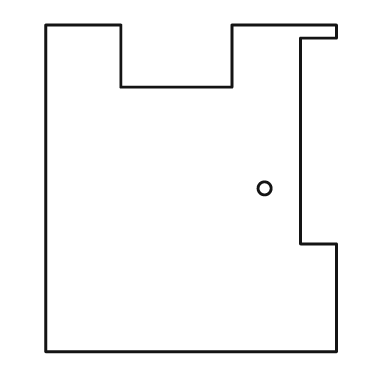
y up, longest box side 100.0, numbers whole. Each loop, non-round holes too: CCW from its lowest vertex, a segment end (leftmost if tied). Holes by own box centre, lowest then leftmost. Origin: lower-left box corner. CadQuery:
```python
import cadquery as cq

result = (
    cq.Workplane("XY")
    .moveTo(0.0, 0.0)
    .lineTo(89.0, 0.0)
    .lineTo(89.0, 33.0)
    .lineTo(78.0, 33.0)
    .lineTo(78.0, 96.0)
    .lineTo(89.0, 96.0)
    .lineTo(89.0, 100.0)
    .lineTo(57.0, 100.0)
    .lineTo(57.0, 81.0)
    .lineTo(23.0, 81.0)
    .lineTo(23.0, 100.0)
    .lineTo(0.0, 100.0)
    .close()
    .moveTo(67.0, 50.0)
    .circle(2.0)
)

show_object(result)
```